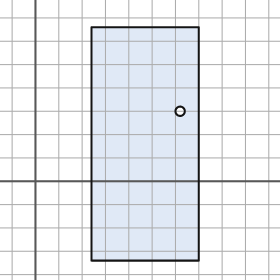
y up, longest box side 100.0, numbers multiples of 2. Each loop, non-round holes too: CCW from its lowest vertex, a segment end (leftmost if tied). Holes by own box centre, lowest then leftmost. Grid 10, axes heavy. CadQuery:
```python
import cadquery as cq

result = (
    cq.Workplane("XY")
    .moveTo(24.0, -34.0)
    .lineTo(70.0, -34.0)
    .lineTo(70.0, 66.0)
    .lineTo(24.0, 66.0)
    .close()
    .moveTo(62.0, 30.0)
    .circle(2.0)
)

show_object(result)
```